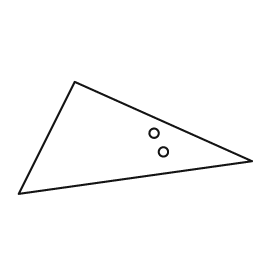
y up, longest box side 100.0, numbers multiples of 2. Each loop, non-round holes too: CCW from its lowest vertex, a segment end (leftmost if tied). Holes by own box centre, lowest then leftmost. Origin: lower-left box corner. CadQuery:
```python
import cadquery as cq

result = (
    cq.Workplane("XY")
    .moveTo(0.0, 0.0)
    .lineTo(100.0, 14.0)
    .lineTo(24.0, 48.0)
    .close()
    .moveTo(62.0, 18.0)
    .circle(2.0)
    .moveTo(58.0, 26.0)
    .circle(2.0)
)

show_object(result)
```